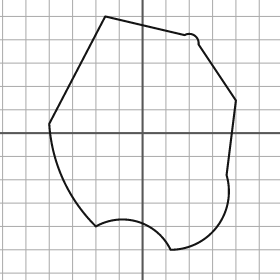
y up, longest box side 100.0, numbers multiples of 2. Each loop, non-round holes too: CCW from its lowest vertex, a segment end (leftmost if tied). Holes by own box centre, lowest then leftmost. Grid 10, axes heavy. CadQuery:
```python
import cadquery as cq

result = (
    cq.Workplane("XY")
    .moveTo(12.0, -50.0)
    .threePointArc((32.0, -40.0), (36.0, -18.0))
    .lineTo(40.0, 14.0)
    .lineTo(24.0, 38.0)
    .threePointArc((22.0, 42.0), (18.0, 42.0))
    .lineTo(-16.0, 50.0)
    .lineTo(-40.0, 4.0)
    .threePointArc((-34.0, -20.0), (-20.0, -40.0))
    .threePointArc((-2.0, -38.0), (12.0, -50.0))
    .close()
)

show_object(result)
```